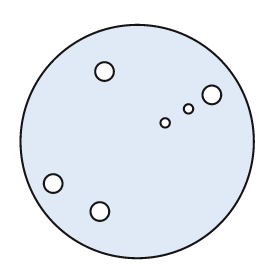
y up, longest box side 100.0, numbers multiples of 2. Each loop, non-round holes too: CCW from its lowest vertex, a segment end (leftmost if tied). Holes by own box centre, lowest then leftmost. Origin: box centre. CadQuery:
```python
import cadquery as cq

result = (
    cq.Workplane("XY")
    .moveTo(0.0, 0.0)
    .circle(50.0)
    .moveTo(-16.0, -30.0)
    .circle(4.0)
    .moveTo(-36.0, -18.0)
    .circle(4.0)
    .moveTo(12.0, 8.0)
    .circle(2.0)
    .moveTo(22.0, 14.0)
    .circle(2.0)
    .moveTo(32.0, 20.0)
    .circle(4.0)
    .moveTo(-14.0, 30.0)
    .circle(4.0)
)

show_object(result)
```